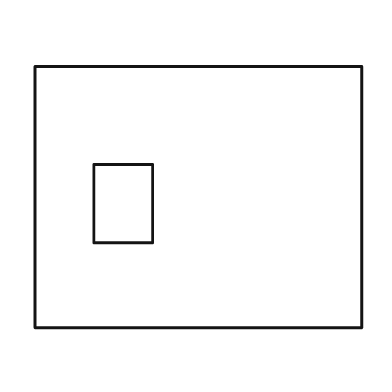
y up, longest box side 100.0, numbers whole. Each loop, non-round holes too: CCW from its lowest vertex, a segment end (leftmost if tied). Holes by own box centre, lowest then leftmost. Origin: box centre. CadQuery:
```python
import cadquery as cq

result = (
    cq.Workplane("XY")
    .moveTo(-50.0, -40.0)
    .lineTo(50.0, -40.0)
    .lineTo(50.0, 40.0)
    .lineTo(-50.0, 40.0)
    .close()
    .moveTo(-32.0, -14.0)
    .lineTo(-14.0, -14.0)
    .lineTo(-14.0, 10.0)
    .lineTo(-32.0, 10.0)
    .close()
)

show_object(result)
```